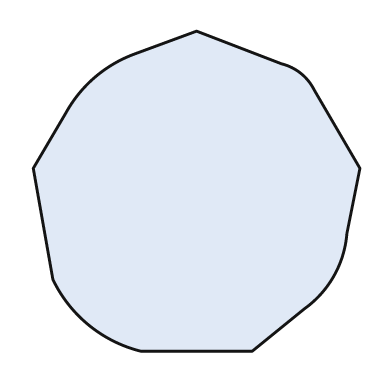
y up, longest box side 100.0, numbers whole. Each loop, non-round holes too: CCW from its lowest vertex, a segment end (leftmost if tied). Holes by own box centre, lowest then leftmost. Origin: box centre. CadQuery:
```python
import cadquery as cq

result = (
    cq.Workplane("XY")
    .moveTo(-17.0, -49.0)
    .lineTo(17.0, -49.0)
    .lineTo(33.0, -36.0)
    .threePointArc((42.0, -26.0), (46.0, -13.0))
    .lineTo(50.0, 7.0)
    .lineTo(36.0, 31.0)
    .threePointArc((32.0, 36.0), (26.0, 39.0))
    .lineTo(0.0, 49.0)
    .lineTo(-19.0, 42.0)
    .threePointArc((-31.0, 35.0), (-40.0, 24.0))
    .lineTo(-50.0, 7.0)
    .lineTo(-44.0, -27.0)
    .threePointArc((-33.0, -41.0), (-17.0, -49.0))
    .close()
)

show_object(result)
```